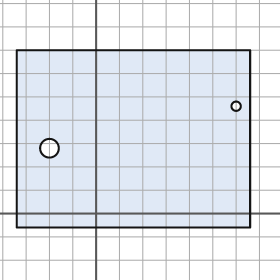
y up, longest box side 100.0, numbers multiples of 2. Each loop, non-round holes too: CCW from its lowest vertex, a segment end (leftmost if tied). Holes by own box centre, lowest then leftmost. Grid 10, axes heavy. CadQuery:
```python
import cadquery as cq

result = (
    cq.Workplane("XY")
    .moveTo(-34.0, -6.0)
    .lineTo(66.0, -6.0)
    .lineTo(66.0, 70.0)
    .lineTo(-34.0, 70.0)
    .close()
    .moveTo(-20.0, 28.0)
    .circle(4.0)
    .moveTo(60.0, 46.0)
    .circle(2.0)
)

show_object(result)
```